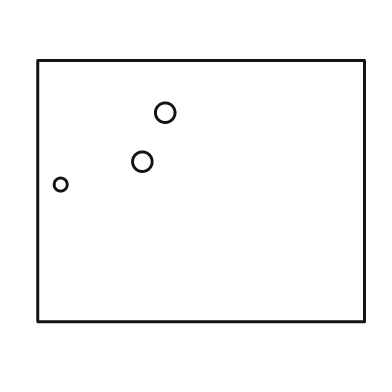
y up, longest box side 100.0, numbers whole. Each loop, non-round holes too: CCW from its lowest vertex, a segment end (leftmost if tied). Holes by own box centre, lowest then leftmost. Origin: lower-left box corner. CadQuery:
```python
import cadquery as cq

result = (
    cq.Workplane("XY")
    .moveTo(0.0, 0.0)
    .lineTo(100.0, 0.0)
    .lineTo(100.0, 80.0)
    .lineTo(0.0, 80.0)
    .close()
    .moveTo(7.0, 42.0)
    .circle(2.0)
    .moveTo(32.0, 49.0)
    .circle(3.0)
    .moveTo(39.0, 64.0)
    .circle(3.0)
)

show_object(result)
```